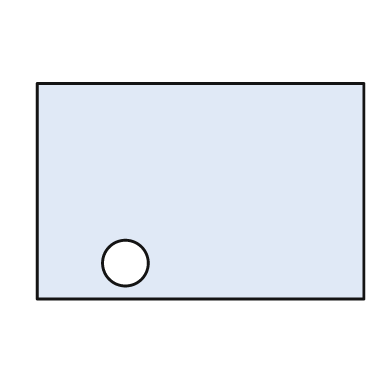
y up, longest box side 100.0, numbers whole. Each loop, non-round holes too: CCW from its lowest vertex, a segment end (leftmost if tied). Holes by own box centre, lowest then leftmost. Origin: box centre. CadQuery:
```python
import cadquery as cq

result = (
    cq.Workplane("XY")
    .moveTo(-50.0, -33.0)
    .lineTo(50.0, -33.0)
    .lineTo(50.0, 33.0)
    .lineTo(-50.0, 33.0)
    .close()
    .moveTo(-23.0, -22.0)
    .circle(7.0)
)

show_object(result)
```